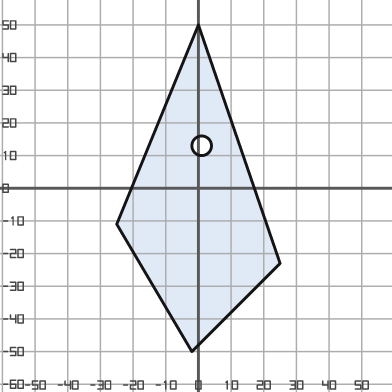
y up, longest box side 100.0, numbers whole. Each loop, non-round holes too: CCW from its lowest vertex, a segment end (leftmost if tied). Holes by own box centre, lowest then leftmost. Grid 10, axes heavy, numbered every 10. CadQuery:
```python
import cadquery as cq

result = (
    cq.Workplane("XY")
    .moveTo(-2.0, -50.0)
    .lineTo(25.0, -23.0)
    .lineTo(0.0, 50.0)
    .lineTo(-25.0, -11.0)
    .close()
    .moveTo(1.0, 13.0)
    .circle(3.0)
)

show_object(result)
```